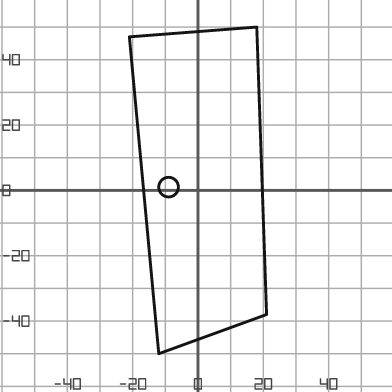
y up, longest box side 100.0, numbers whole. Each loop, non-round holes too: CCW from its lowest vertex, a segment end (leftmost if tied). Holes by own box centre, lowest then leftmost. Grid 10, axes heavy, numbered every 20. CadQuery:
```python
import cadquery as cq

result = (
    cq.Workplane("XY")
    .moveTo(-12.0, -50.0)
    .lineTo(21.0, -38.0)
    .lineTo(18.0, 50.0)
    .lineTo(-21.0, 47.0)
    .close()
    .moveTo(-9.0, 1.0)
    .circle(3.0)
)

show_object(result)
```